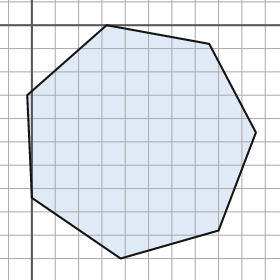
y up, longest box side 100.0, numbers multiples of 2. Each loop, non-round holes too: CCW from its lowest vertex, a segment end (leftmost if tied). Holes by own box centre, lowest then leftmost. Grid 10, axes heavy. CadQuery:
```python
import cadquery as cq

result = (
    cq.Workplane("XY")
    .moveTo(38.0, -100.0)
    .lineTo(80.0, -88.0)
    .lineTo(96.0, -46.0)
    .lineTo(76.0, -8.0)
    .lineTo(32.0, 0.0)
    .lineTo(-2.0, -30.0)
    .lineTo(0.0, -74.0)
    .close()
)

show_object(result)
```